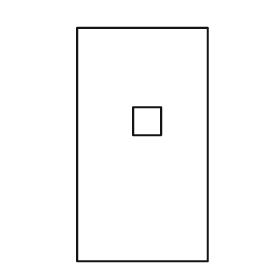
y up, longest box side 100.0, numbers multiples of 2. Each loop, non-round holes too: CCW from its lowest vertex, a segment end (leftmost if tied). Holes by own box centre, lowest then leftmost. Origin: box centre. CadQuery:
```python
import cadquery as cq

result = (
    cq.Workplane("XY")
    .moveTo(-28.0, -50.0)
    .lineTo(28.0, -50.0)
    .lineTo(28.0, 50.0)
    .lineTo(-28.0, 50.0)
    .close()
    .moveTo(-4.0, 4.0)
    .lineTo(8.0, 4.0)
    .lineTo(8.0, 16.0)
    .lineTo(-4.0, 16.0)
    .close()
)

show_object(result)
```